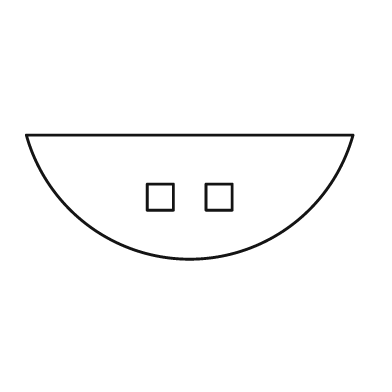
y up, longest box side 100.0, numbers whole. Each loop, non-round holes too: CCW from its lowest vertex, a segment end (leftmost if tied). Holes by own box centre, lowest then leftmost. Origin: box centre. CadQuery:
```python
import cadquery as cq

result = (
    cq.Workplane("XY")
    .moveTo(-50.0, 19.0)
    .threePointArc((0.0, -19.0), (50.0, 19.0))
    .close()
    .moveTo(-13.0, -4.0)
    .lineTo(-5.0, -4.0)
    .lineTo(-5.0, 4.0)
    .lineTo(-13.0, 4.0)
    .close()
    .moveTo(5.0, -4.0)
    .lineTo(13.0, -4.0)
    .lineTo(13.0, 4.0)
    .lineTo(5.0, 4.0)
    .close()
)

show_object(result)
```